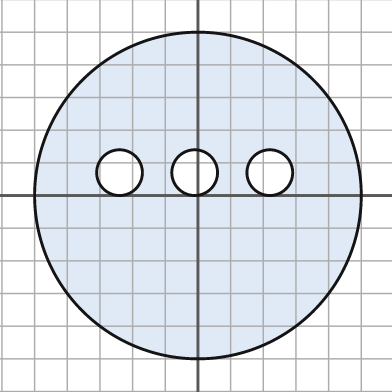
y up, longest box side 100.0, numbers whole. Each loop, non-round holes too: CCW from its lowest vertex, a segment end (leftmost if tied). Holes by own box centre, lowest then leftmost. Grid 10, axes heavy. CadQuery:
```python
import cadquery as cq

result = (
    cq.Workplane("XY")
    .moveTo(0.0, 0.0)
    .circle(50.0)
    .moveTo(-24.0, 7.0)
    .circle(7.0)
    .moveTo(-1.0, 7.0)
    .circle(7.0)
    .moveTo(22.0, 7.0)
    .circle(7.0)
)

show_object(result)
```